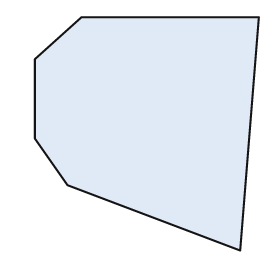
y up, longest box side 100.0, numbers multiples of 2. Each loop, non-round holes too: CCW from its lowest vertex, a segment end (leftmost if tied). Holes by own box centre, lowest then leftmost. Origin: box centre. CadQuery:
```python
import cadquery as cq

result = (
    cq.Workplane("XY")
    .moveTo(40.0, -50.0)
    .lineTo(48.0, 50.0)
    .lineTo(-28.0, 50.0)
    .lineTo(-48.0, 32.0)
    .lineTo(-48.0, -2.0)
    .lineTo(-34.0, -22.0)
    .close()
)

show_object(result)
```